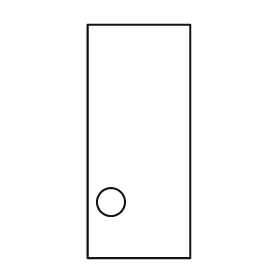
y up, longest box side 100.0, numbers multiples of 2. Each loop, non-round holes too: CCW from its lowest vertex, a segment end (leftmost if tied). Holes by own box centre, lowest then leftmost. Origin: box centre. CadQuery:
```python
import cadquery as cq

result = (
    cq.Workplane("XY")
    .moveTo(-22.0, -50.0)
    .lineTo(22.0, -50.0)
    .lineTo(22.0, 50.0)
    .lineTo(-22.0, 50.0)
    .close()
    .moveTo(-12.0, -26.0)
    .circle(6.0)
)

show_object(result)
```